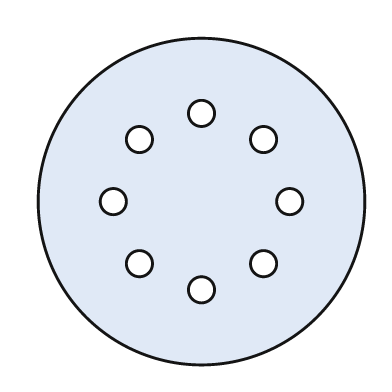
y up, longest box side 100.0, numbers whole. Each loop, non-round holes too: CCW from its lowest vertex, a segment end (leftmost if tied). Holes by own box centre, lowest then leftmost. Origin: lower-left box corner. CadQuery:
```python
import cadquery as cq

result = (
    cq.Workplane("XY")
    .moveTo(50.0, 50.0)
    .circle(50.0)
    .moveTo(50.0, 23.0)
    .circle(4.0)
    .moveTo(31.0, 31.0)
    .circle(4.0)
    .moveTo(69.0, 31.0)
    .circle(4.0)
    .moveTo(23.0, 50.0)
    .circle(4.0)
    .moveTo(77.0, 50.0)
    .circle(4.0)
    .moveTo(31.0, 69.0)
    .circle(4.0)
    .moveTo(69.0, 69.0)
    .circle(4.0)
    .moveTo(50.0, 77.0)
    .circle(4.0)
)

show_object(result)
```